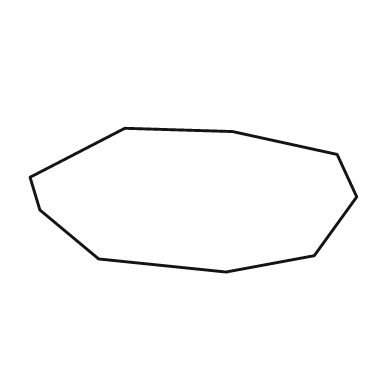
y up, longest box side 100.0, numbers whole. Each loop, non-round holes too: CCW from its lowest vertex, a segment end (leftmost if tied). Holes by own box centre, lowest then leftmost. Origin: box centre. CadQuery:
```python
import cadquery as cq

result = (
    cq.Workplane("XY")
    .moveTo(10.0, -22.0)
    .lineTo(37.0, -17.0)
    .lineTo(50.0, 1.0)
    .lineTo(44.0, 14.0)
    .lineTo(12.0, 21.0)
    .lineTo(-21.0, 22.0)
    .lineTo(-50.0, 7.0)
    .lineTo(-47.0, -3.0)
    .lineTo(-29.0, -18.0)
    .close()
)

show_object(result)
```